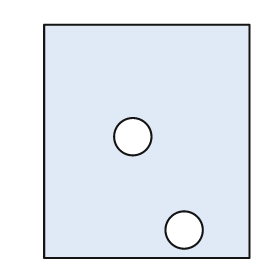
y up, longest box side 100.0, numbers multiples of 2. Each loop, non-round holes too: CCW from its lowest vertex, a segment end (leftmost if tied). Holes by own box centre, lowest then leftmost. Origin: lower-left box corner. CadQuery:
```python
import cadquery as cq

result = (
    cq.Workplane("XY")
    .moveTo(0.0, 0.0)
    .lineTo(88.0, 0.0)
    .lineTo(88.0, 100.0)
    .lineTo(0.0, 100.0)
    .close()
    .moveTo(60.0, 12.0)
    .circle(8.0)
    .moveTo(38.0, 52.0)
    .circle(8.0)
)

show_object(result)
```